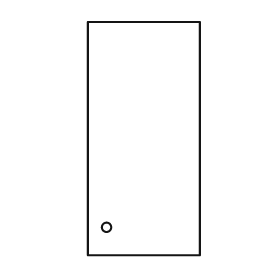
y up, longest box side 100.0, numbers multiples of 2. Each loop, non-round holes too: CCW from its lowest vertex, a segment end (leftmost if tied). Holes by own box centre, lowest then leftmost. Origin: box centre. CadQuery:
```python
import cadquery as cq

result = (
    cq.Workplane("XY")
    .moveTo(-24.0, -50.0)
    .lineTo(24.0, -50.0)
    .lineTo(24.0, 50.0)
    .lineTo(-24.0, 50.0)
    .close()
    .moveTo(-16.0, -38.0)
    .circle(2.0)
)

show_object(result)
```